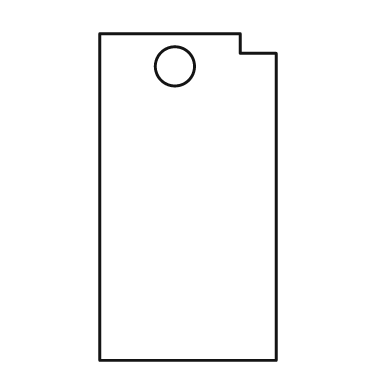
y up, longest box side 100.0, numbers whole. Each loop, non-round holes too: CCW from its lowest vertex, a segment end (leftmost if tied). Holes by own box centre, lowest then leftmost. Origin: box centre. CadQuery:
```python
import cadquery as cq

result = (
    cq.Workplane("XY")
    .moveTo(-27.0, -50.0)
    .lineTo(27.0, -50.0)
    .lineTo(27.0, 44.0)
    .lineTo(16.0, 44.0)
    .lineTo(16.0, 50.0)
    .lineTo(-27.0, 50.0)
    .close()
    .moveTo(-4.0, 40.0)
    .circle(6.0)
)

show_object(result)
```